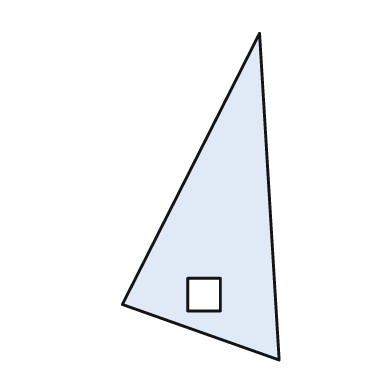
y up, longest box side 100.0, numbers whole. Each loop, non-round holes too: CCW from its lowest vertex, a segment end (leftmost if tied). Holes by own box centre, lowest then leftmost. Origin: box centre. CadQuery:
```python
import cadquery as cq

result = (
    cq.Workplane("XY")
    .moveTo(24.0, -50.0)
    .lineTo(18.0, 50.0)
    .lineTo(-24.0, -33.0)
    .close()
    .moveTo(-4.0, -35.0)
    .lineTo(6.0, -35.0)
    .lineTo(6.0, -25.0)
    .lineTo(-4.0, -25.0)
    .close()
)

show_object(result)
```